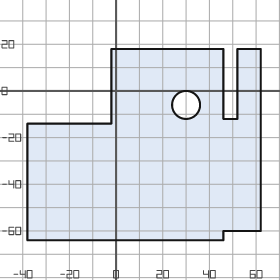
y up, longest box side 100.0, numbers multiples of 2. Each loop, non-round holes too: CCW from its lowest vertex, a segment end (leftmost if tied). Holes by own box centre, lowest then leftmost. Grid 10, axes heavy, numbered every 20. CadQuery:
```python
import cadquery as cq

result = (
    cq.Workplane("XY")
    .moveTo(-38.0, -64.0)
    .lineTo(46.0, -64.0)
    .lineTo(46.0, -60.0)
    .lineTo(62.0, -60.0)
    .lineTo(62.0, 18.0)
    .lineTo(52.0, 18.0)
    .lineTo(52.0, -12.0)
    .lineTo(46.0, -12.0)
    .lineTo(46.0, 18.0)
    .lineTo(-2.0, 18.0)
    .lineTo(-2.0, -14.0)
    .lineTo(-38.0, -14.0)
    .close()
    .moveTo(30.0, -6.0)
    .circle(6.0)
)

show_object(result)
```